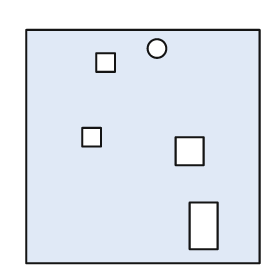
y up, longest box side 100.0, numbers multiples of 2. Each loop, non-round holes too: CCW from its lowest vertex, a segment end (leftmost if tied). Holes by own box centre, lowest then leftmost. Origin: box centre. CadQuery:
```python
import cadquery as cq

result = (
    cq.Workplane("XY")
    .moveTo(-50.0, -50.0)
    .lineTo(50.0, -50.0)
    .lineTo(50.0, 50.0)
    .lineTo(-50.0, 50.0)
    .close()
    .moveTo(20.0, -44.0)
    .lineTo(32.0, -44.0)
    .lineTo(32.0, -24.0)
    .lineTo(20.0, -24.0)
    .close()
    .moveTo(14.0, -8.0)
    .lineTo(26.0, -8.0)
    .lineTo(26.0, 4.0)
    .lineTo(14.0, 4.0)
    .close()
    .moveTo(-26.0, 0.0)
    .lineTo(-18.0, 0.0)
    .lineTo(-18.0, 8.0)
    .lineTo(-26.0, 8.0)
    .close()
    .moveTo(-20.0, 32.0)
    .lineTo(-12.0, 32.0)
    .lineTo(-12.0, 40.0)
    .lineTo(-20.0, 40.0)
    .close()
    .moveTo(6.0, 42.0)
    .circle(4.0)
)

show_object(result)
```